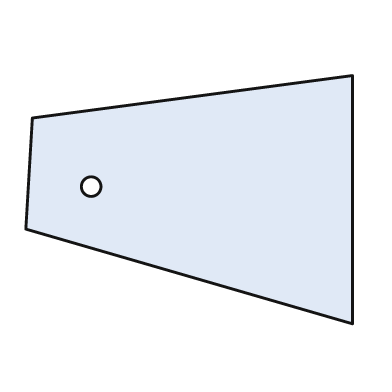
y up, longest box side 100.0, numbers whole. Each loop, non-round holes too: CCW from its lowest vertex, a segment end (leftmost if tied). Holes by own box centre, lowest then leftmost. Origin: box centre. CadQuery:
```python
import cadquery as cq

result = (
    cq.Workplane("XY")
    .moveTo(50.0, -38.0)
    .lineTo(50.0, 38.0)
    .lineTo(-48.0, 25.0)
    .lineTo(-50.0, -9.0)
    .close()
    .moveTo(-30.0, 4.0)
    .circle(3.0)
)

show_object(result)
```